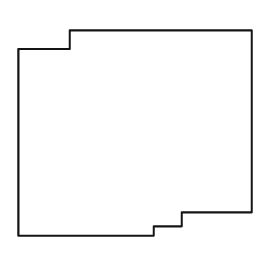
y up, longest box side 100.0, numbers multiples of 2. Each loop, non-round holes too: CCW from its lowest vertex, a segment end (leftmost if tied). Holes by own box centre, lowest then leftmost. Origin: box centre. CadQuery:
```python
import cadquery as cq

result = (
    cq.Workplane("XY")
    .moveTo(-50.0, -44.0)
    .lineTo(8.0, -44.0)
    .lineTo(8.0, -40.0)
    .lineTo(20.0, -40.0)
    .lineTo(20.0, -34.0)
    .lineTo(50.0, -34.0)
    .lineTo(50.0, 44.0)
    .lineTo(-28.0, 44.0)
    .lineTo(-28.0, 36.0)
    .lineTo(-50.0, 36.0)
    .close()
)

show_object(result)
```